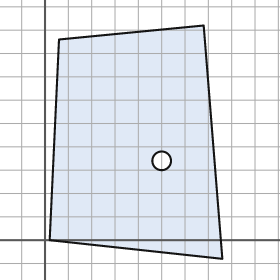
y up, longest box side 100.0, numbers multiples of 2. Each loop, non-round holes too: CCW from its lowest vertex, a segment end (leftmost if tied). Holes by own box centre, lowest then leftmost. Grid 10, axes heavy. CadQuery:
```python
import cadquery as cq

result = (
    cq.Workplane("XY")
    .moveTo(76.0, -8.0)
    .lineTo(68.0, 92.0)
    .lineTo(6.0, 86.0)
    .lineTo(2.0, 0.0)
    .close()
    .moveTo(50.0, 34.0)
    .circle(4.0)
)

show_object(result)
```